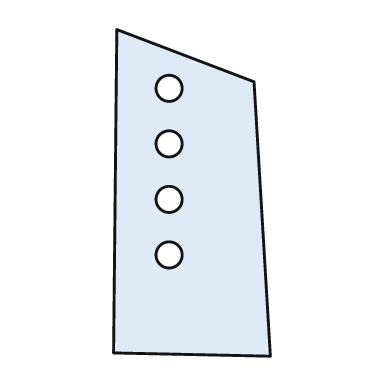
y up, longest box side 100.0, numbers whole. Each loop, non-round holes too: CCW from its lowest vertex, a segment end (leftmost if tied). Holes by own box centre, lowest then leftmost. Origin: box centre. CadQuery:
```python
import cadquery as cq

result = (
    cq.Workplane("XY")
    .moveTo(24.0, -50.0)
    .lineTo(19.0, 34.0)
    .lineTo(-23.0, 50.0)
    .lineTo(-24.0, -49.0)
    .close()
    .moveTo(-7.0, -19.0)
    .circle(4.0)
    .moveTo(-7.0, -2.0)
    .circle(4.0)
    .moveTo(-7.0, 15.0)
    .circle(4.0)
    .moveTo(-7.0, 32.0)
    .circle(4.0)
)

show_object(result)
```